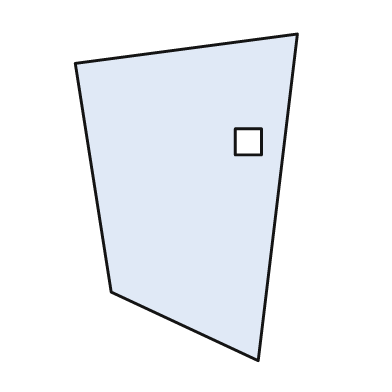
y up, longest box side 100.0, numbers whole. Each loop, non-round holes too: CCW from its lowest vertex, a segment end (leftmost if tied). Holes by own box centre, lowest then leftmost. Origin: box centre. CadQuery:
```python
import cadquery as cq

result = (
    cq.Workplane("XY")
    .moveTo(22.0, -50.0)
    .lineTo(34.0, 50.0)
    .lineTo(-34.0, 41.0)
    .lineTo(-23.0, -29.0)
    .close()
    .moveTo(15.0, 13.0)
    .lineTo(23.0, 13.0)
    .lineTo(23.0, 21.0)
    .lineTo(15.0, 21.0)
    .close()
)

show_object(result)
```